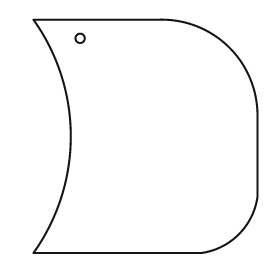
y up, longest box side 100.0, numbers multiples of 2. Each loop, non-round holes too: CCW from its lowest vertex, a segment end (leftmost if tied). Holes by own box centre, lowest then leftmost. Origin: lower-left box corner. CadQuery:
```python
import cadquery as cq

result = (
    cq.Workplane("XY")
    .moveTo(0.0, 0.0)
    .lineTo(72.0, 0.0)
    .threePointArc((88.0, 8.0), (96.0, 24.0))
    .lineTo(96.0, 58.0)
    .threePointArc((84.0, 88.0), (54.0, 100.0))
    .lineTo(0.0, 100.0)
    .threePointArc((16.0, 50.0), (0.0, 0.0))
    .close()
    .moveTo(20.0, 92.0)
    .circle(2.0)
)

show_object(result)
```